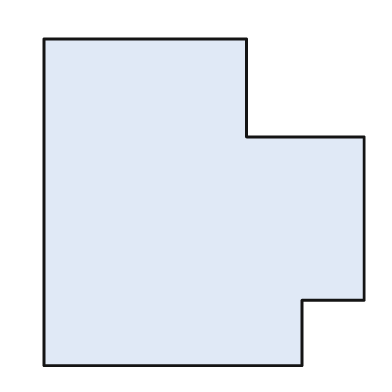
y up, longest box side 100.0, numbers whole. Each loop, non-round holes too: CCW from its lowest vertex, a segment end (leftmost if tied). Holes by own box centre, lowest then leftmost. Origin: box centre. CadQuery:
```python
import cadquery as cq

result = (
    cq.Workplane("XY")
    .moveTo(-49.0, -50.0)
    .lineTo(30.0, -50.0)
    .lineTo(30.0, -30.0)
    .lineTo(49.0, -30.0)
    .lineTo(49.0, 20.0)
    .lineTo(13.0, 20.0)
    .lineTo(13.0, 50.0)
    .lineTo(-49.0, 50.0)
    .close()
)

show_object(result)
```